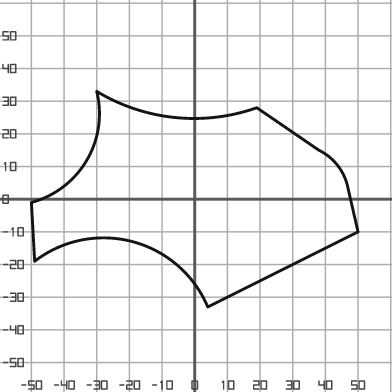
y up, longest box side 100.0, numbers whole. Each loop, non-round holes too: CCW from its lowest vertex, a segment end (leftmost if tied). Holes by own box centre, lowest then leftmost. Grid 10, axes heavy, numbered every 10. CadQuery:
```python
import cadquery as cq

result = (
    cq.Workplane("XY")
    .moveTo(4.0, -33.0)
    .lineTo(50.0, -10.0)
    .lineTo(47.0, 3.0)
    .threePointArc((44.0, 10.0), (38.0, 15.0))
    .lineTo(19.0, 28.0)
    .threePointArc((-6.0, 25.0), (-30.0, 33.0))
    .threePointArc((-33.0, 12.0), (-50.0, -1.0))
    .lineTo(-49.0, -19.0)
    .threePointArc((-19.0, -13.0), (4.0, -33.0))
    .close()
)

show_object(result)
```